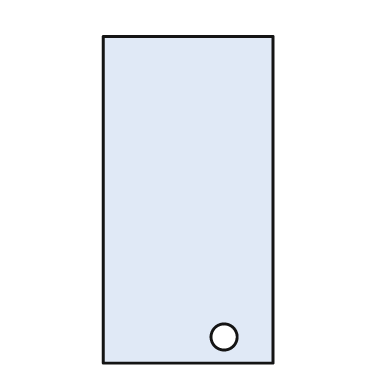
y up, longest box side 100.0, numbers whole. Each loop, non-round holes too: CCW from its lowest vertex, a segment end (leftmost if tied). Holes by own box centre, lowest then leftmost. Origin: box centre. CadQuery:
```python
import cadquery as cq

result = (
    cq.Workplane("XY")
    .moveTo(-26.0, -50.0)
    .lineTo(26.0, -50.0)
    .lineTo(26.0, 50.0)
    .lineTo(-26.0, 50.0)
    .close()
    .moveTo(11.0, -42.0)
    .circle(4.0)
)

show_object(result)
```